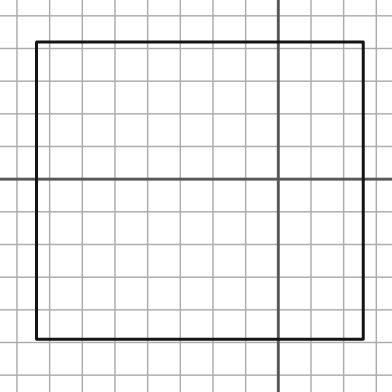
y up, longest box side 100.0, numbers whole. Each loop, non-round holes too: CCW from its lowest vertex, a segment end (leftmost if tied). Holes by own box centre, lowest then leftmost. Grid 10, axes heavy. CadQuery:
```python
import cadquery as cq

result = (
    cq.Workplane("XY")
    .moveTo(-74.0, -49.0)
    .lineTo(26.0, -49.0)
    .lineTo(26.0, 42.0)
    .lineTo(-74.0, 42.0)
    .close()
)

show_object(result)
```